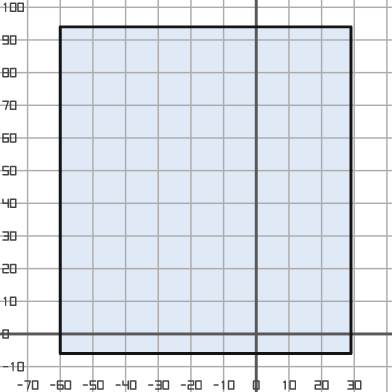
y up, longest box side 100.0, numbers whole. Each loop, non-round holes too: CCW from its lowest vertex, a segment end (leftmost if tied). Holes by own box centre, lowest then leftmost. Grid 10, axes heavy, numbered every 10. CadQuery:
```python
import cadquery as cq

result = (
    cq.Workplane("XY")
    .moveTo(-60.0, -6.0)
    .lineTo(29.0, -6.0)
    .lineTo(29.0, 94.0)
    .lineTo(-60.0, 94.0)
    .close()
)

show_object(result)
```